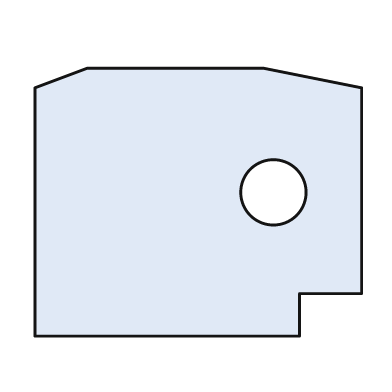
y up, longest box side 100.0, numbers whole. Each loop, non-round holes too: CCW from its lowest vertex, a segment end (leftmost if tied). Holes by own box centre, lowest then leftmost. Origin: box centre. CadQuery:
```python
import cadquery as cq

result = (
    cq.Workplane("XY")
    .moveTo(-50.0, -41.0)
    .lineTo(31.0, -41.0)
    .lineTo(31.0, -28.0)
    .lineTo(50.0, -28.0)
    .lineTo(50.0, 35.0)
    .lineTo(20.0, 41.0)
    .lineTo(-34.0, 41.0)
    .lineTo(-50.0, 35.0)
    .close()
    .moveTo(23.0, 3.0)
    .circle(10.0)
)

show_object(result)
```